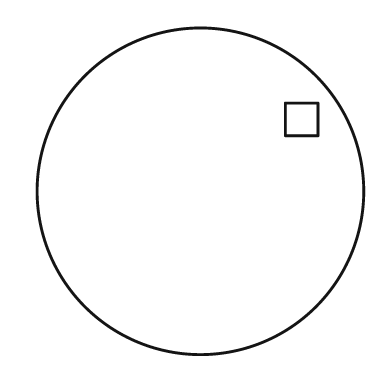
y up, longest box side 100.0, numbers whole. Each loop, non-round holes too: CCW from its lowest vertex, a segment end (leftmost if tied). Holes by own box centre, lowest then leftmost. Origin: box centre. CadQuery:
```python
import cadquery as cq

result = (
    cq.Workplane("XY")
    .moveTo(0.0, 0.0)
    .circle(50.0)
    .moveTo(26.0, 17.0)
    .lineTo(36.0, 17.0)
    .lineTo(36.0, 27.0)
    .lineTo(26.0, 27.0)
    .close()
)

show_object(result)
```